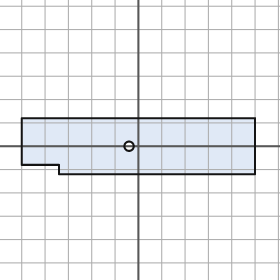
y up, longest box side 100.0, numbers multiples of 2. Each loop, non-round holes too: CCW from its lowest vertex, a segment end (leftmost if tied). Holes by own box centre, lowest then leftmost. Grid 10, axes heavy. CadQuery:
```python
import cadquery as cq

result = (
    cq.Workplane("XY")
    .moveTo(-34.0, -12.0)
    .lineTo(50.0, -12.0)
    .lineTo(50.0, 12.0)
    .lineTo(-50.0, 12.0)
    .lineTo(-50.0, -8.0)
    .lineTo(-34.0, -8.0)
    .close()
    .moveTo(-4.0, 0.0)
    .circle(2.0)
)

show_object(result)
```